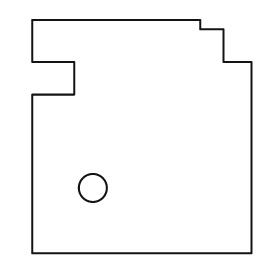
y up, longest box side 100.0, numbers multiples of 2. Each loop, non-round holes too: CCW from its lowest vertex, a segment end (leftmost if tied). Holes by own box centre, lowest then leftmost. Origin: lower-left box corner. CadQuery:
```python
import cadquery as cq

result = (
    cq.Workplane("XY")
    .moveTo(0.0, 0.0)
    .lineTo(94.0, 0.0)
    .lineTo(94.0, 82.0)
    .lineTo(82.0, 82.0)
    .lineTo(82.0, 96.0)
    .lineTo(72.0, 96.0)
    .lineTo(72.0, 100.0)
    .lineTo(0.0, 100.0)
    .lineTo(0.0, 82.0)
    .lineTo(18.0, 82.0)
    .lineTo(18.0, 68.0)
    .lineTo(0.0, 68.0)
    .close()
    .moveTo(26.0, 28.0)
    .circle(6.0)
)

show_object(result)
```